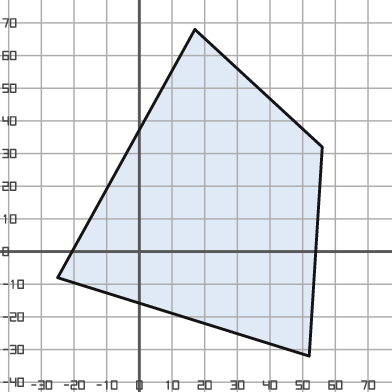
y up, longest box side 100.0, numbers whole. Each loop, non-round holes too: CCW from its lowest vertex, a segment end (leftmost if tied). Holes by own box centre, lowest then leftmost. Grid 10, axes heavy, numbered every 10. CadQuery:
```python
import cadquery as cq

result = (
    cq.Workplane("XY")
    .moveTo(52.0, -32.0)
    .lineTo(56.0, 32.0)
    .lineTo(17.0, 68.0)
    .lineTo(-25.0, -8.0)
    .close()
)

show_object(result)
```